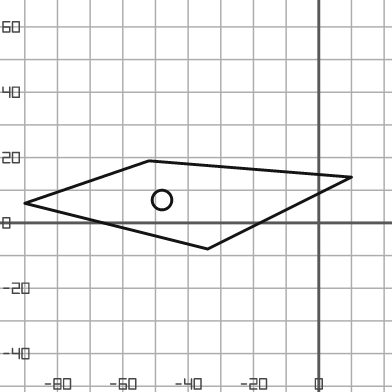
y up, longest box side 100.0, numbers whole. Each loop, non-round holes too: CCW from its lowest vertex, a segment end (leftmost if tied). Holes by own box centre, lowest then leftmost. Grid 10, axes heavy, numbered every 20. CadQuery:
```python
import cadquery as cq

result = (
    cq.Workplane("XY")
    .moveTo(-34.0, -8.0)
    .lineTo(10.0, 14.0)
    .lineTo(-52.0, 19.0)
    .lineTo(-90.0, 6.0)
    .close()
    .moveTo(-48.0, 7.0)
    .circle(3.0)
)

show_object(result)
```